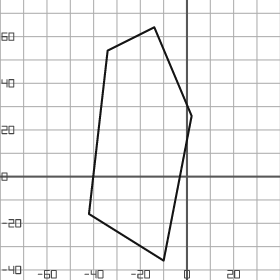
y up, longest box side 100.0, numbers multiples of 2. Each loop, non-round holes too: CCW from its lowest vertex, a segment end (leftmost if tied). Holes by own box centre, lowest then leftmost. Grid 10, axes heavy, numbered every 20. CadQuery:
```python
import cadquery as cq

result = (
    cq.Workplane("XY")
    .moveTo(-10.0, -36.0)
    .lineTo(2.0, 26.0)
    .lineTo(-14.0, 64.0)
    .lineTo(-34.0, 54.0)
    .lineTo(-42.0, -16.0)
    .close()
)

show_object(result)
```